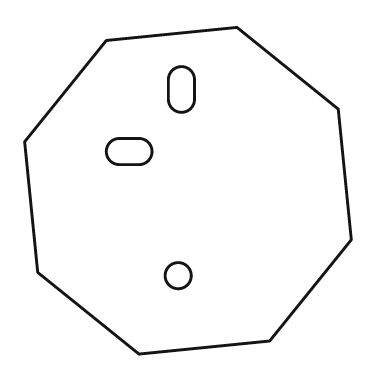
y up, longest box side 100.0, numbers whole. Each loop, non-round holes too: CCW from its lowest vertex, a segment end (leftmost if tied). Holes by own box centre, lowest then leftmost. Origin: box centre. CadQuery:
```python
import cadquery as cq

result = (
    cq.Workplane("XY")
    .moveTo(-15.0, -50.0)
    .lineTo(25.0, -46.0)
    .lineTo(50.0, -15.0)
    .lineTo(46.0, 25.0)
    .lineTo(15.0, 50.0)
    .lineTo(-25.0, 46.0)
    .lineTo(-50.0, 15.0)
    .lineTo(-46.0, -25.0)
    .close()
    .moveTo(-3.0, -26.0)
    .circle(4.0)
    .moveTo(-21.0, 8.0)
    .lineTo(-15.0, 8.0)
    .threePointArc((-11.0, 12.0), (-15.0, 16.0))
    .lineTo(-21.0, 16.0)
    .threePointArc((-25.0, 12.0), (-21.0, 8.0))
    .close()
    .moveTo(-6.0, 28.0)
    .threePointArc((-2.0, 24.0), (2.0, 28.0))
    .lineTo(2.0, 34.0)
    .threePointArc((-2.0, 38.0), (-6.0, 34.0))
    .close()
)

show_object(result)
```